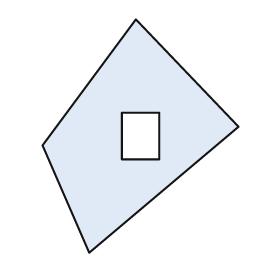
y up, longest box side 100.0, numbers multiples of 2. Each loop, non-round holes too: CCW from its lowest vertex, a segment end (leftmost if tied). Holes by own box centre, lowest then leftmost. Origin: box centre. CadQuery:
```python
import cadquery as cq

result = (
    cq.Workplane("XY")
    .moveTo(-22.0, -50.0)
    .lineTo(42.0, 4.0)
    .lineTo(-2.0, 50.0)
    .lineTo(-42.0, -4.0)
    .close()
    .moveTo(-8.0, -10.0)
    .lineTo(8.0, -10.0)
    .lineTo(8.0, 10.0)
    .lineTo(-8.0, 10.0)
    .close()
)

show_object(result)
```